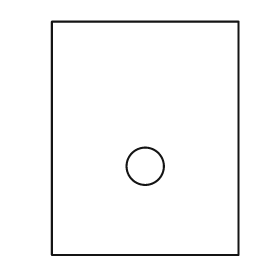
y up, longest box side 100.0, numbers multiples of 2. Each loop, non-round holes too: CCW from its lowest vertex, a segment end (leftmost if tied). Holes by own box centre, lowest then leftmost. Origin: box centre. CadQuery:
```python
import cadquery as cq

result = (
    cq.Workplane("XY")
    .moveTo(-40.0, -50.0)
    .lineTo(40.0, -50.0)
    .lineTo(40.0, 50.0)
    .lineTo(-40.0, 50.0)
    .close()
    .moveTo(0.0, -12.0)
    .circle(8.0)
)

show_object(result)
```